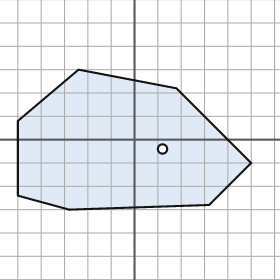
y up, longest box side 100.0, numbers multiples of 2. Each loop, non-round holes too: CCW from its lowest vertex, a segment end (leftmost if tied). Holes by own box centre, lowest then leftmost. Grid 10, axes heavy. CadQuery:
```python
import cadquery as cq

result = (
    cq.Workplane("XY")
    .moveTo(-28.0, -30.0)
    .lineTo(32.0, -28.0)
    .lineTo(50.0, -10.0)
    .lineTo(18.0, 22.0)
    .lineTo(-24.0, 30.0)
    .lineTo(-50.0, 8.0)
    .lineTo(-50.0, -24.0)
    .close()
    .moveTo(12.0, -4.0)
    .circle(2.0)
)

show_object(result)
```